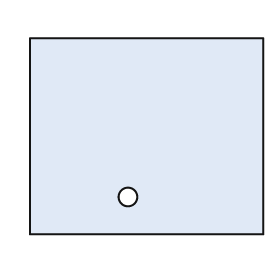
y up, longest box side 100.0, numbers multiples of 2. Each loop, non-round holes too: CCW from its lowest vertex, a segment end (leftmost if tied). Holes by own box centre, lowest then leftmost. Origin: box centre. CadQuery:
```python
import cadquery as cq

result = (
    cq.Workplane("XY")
    .moveTo(-50.0, -42.0)
    .lineTo(50.0, -42.0)
    .lineTo(50.0, 42.0)
    .lineTo(-50.0, 42.0)
    .close()
    .moveTo(-8.0, -26.0)
    .circle(4.0)
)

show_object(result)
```